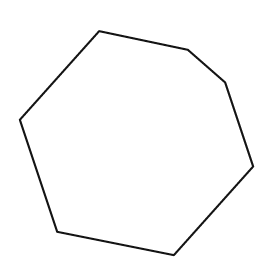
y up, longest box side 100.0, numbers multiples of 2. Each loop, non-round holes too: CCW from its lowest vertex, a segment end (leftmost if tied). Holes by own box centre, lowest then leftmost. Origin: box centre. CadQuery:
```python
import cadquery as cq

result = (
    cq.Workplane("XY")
    .moveTo(16.0, -48.0)
    .lineTo(50.0, -10.0)
    .lineTo(38.0, 26.0)
    .lineTo(22.0, 40.0)
    .lineTo(-16.0, 48.0)
    .lineTo(-50.0, 10.0)
    .lineTo(-34.0, -38.0)
    .close()
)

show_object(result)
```